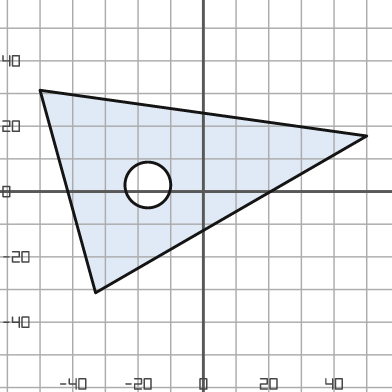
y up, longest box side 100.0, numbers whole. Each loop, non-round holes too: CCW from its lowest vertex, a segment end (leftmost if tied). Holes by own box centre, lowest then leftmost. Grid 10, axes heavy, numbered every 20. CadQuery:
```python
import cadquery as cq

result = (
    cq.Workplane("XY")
    .moveTo(-33.0, -31.0)
    .lineTo(50.0, 17.0)
    .lineTo(-50.0, 31.0)
    .close()
    .moveTo(-17.0, 2.0)
    .circle(7.0)
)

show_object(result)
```